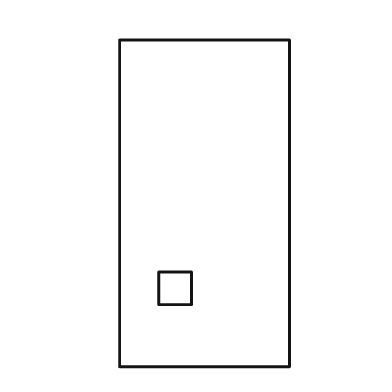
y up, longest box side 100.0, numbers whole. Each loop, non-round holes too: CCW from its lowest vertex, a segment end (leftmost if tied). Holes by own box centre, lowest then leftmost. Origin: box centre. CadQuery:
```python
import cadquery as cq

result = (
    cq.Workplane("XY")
    .moveTo(-26.0, -50.0)
    .lineTo(26.0, -50.0)
    .lineTo(26.0, 50.0)
    .lineTo(-26.0, 50.0)
    .close()
    .moveTo(-14.0, -31.0)
    .lineTo(-4.0, -31.0)
    .lineTo(-4.0, -21.0)
    .lineTo(-14.0, -21.0)
    .close()
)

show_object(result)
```